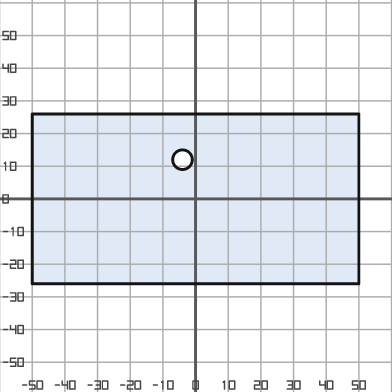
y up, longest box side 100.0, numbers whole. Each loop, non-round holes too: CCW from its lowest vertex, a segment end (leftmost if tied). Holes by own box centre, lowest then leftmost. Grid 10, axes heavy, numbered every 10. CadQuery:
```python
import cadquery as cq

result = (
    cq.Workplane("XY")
    .moveTo(-50.0, -26.0)
    .lineTo(50.0, -26.0)
    .lineTo(50.0, 26.0)
    .lineTo(-50.0, 26.0)
    .close()
    .moveTo(-4.0, 12.0)
    .circle(3.0)
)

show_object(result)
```